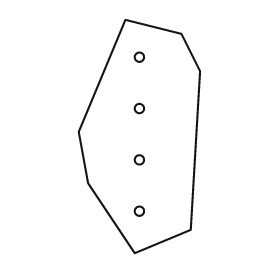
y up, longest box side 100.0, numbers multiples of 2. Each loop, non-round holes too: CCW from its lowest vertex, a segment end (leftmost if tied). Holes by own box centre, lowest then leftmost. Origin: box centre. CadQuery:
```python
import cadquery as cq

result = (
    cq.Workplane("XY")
    .moveTo(-2.0, -50.0)
    .lineTo(22.0, -40.0)
    .lineTo(26.0, 28.0)
    .lineTo(18.0, 44.0)
    .lineTo(-6.0, 50.0)
    .lineTo(-26.0, 2.0)
    .lineTo(-22.0, -20.0)
    .close()
    .moveTo(0.0, -32.0)
    .circle(2.0)
    .moveTo(0.0, -10.0)
    .circle(2.0)
    .moveTo(0.0, 12.0)
    .circle(2.0)
    .moveTo(0.0, 34.0)
    .circle(2.0)
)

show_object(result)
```